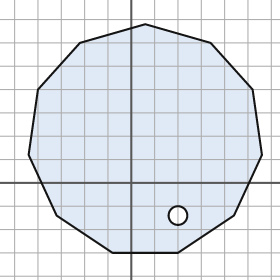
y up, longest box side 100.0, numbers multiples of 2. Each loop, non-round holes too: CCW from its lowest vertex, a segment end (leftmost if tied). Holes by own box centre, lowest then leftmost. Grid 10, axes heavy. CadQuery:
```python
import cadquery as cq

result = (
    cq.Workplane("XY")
    .moveTo(-8.0, -30.0)
    .lineTo(20.0, -30.0)
    .lineTo(44.0, -14.0)
    .lineTo(56.0, 12.0)
    .lineTo(52.0, 40.0)
    .lineTo(34.0, 60.0)
    .lineTo(6.0, 68.0)
    .lineTo(-22.0, 60.0)
    .lineTo(-40.0, 40.0)
    .lineTo(-44.0, 12.0)
    .lineTo(-32.0, -14.0)
    .close()
    .moveTo(20.0, -14.0)
    .circle(4.0)
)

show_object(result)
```